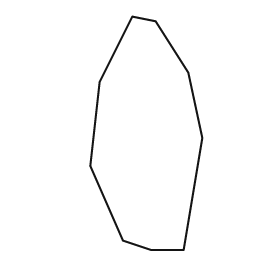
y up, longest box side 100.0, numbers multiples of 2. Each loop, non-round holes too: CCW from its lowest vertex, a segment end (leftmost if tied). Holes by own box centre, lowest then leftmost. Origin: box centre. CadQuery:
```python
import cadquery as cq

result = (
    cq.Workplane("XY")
    .moveTo(2.0, -50.0)
    .lineTo(16.0, -50.0)
    .lineTo(24.0, -2.0)
    .lineTo(18.0, 26.0)
    .lineTo(4.0, 48.0)
    .lineTo(-6.0, 50.0)
    .lineTo(-20.0, 22.0)
    .lineTo(-24.0, -14.0)
    .lineTo(-10.0, -46.0)
    .close()
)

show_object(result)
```